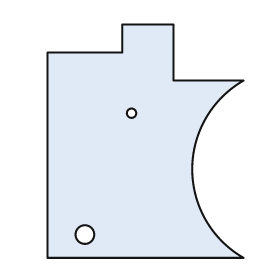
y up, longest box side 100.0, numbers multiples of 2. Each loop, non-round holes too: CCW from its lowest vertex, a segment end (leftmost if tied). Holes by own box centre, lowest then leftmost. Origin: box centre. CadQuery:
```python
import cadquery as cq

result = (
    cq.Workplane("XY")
    .moveTo(-42.0, -50.0)
    .lineTo(42.0, -50.0)
    .threePointArc((20.0, -12.0), (42.0, 26.0))
    .lineTo(12.0, 26.0)
    .lineTo(12.0, 50.0)
    .lineTo(-10.0, 50.0)
    .lineTo(-10.0, 38.0)
    .lineTo(-42.0, 38.0)
    .close()
    .moveTo(-26.0, -40.0)
    .circle(4.0)
    .moveTo(-6.0, 12.0)
    .circle(2.0)
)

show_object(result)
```